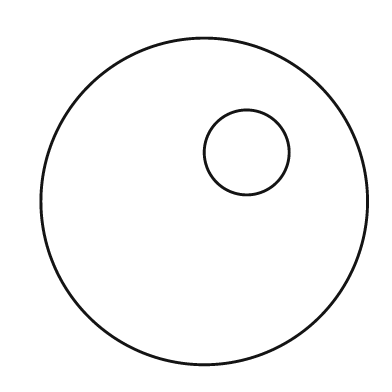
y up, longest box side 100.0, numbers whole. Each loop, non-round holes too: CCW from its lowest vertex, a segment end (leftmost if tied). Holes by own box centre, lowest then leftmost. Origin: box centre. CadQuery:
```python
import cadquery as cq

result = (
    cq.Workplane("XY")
    .moveTo(0.0, 0.0)
    .circle(50.0)
    .moveTo(13.0, 15.0)
    .circle(13.0)
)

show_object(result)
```